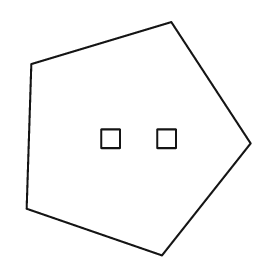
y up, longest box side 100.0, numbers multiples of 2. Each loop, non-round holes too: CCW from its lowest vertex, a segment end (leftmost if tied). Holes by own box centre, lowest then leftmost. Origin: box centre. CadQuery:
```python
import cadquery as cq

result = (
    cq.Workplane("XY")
    .moveTo(10.0, -50.0)
    .lineTo(48.0, -2.0)
    .lineTo(14.0, 50.0)
    .lineTo(-46.0, 32.0)
    .lineTo(-48.0, -30.0)
    .close()
    .moveTo(-16.0, -4.0)
    .lineTo(-8.0, -4.0)
    .lineTo(-8.0, 4.0)
    .lineTo(-16.0, 4.0)
    .close()
    .moveTo(8.0, -4.0)
    .lineTo(16.0, -4.0)
    .lineTo(16.0, 4.0)
    .lineTo(8.0, 4.0)
    .close()
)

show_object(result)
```